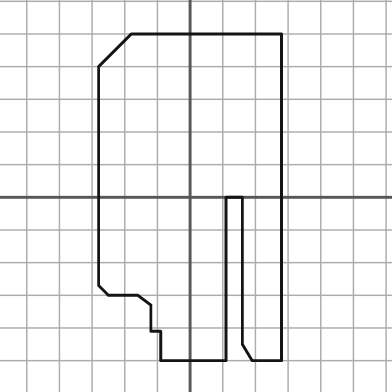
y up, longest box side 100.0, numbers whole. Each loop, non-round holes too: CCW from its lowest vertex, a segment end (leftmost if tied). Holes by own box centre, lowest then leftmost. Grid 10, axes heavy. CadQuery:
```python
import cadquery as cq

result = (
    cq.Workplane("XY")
    .moveTo(-9.0, -50.0)
    .lineTo(11.0, -50.0)
    .lineTo(11.0, 0.0)
    .lineTo(16.0, 0.0)
    .lineTo(16.0, -45.0)
    .lineTo(19.0, -50.0)
    .lineTo(28.0, -50.0)
    .lineTo(28.0, 50.0)
    .lineTo(-18.0, 50.0)
    .lineTo(-28.0, 40.0)
    .lineTo(-28.0, -27.0)
    .lineTo(-25.0, -30.0)
    .lineTo(-16.0, -30.0)
    .lineTo(-12.0, -33.0)
    .lineTo(-12.0, -41.0)
    .lineTo(-9.0, -41.0)
    .close()
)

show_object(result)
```